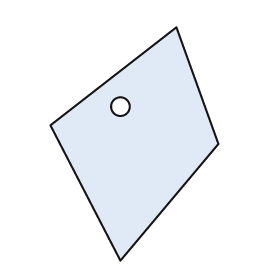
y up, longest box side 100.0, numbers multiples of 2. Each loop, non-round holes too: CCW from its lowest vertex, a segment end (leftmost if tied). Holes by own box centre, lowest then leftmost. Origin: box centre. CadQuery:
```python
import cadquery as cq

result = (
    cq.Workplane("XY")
    .moveTo(-6.0, -50.0)
    .lineTo(36.0, 0.0)
    .lineTo(18.0, 50.0)
    .lineTo(-36.0, 8.0)
    .close()
    .moveTo(-6.0, 16.0)
    .circle(4.0)
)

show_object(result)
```